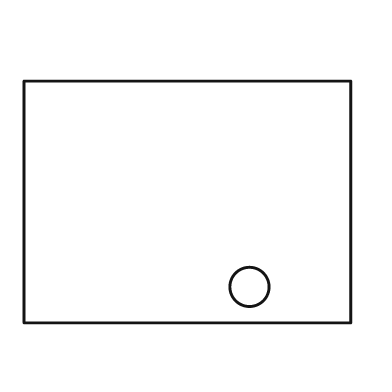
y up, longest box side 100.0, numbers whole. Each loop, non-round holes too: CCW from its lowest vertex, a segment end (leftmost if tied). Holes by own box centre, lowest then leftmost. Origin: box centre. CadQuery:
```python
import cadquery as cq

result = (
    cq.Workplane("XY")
    .moveTo(-50.0, -37.0)
    .lineTo(50.0, -37.0)
    .lineTo(50.0, 37.0)
    .lineTo(-50.0, 37.0)
    .close()
    .moveTo(19.0, -26.0)
    .circle(6.0)
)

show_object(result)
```